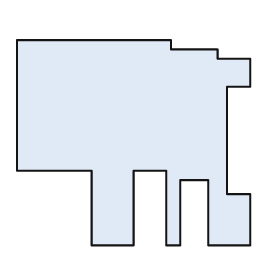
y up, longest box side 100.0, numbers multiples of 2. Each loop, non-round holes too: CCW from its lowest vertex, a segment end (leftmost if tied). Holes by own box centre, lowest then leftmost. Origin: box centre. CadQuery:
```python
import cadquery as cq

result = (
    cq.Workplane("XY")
    .moveTo(-18.0, -44.0)
    .lineTo(0.0, -44.0)
    .lineTo(0.0, -12.0)
    .lineTo(14.0, -12.0)
    .lineTo(14.0, -44.0)
    .lineTo(20.0, -44.0)
    .lineTo(20.0, -16.0)
    .lineTo(32.0, -16.0)
    .lineTo(32.0, -44.0)
    .lineTo(50.0, -44.0)
    .lineTo(50.0, -22.0)
    .lineTo(40.0, -22.0)
    .lineTo(40.0, 24.0)
    .lineTo(50.0, 24.0)
    .lineTo(50.0, 36.0)
    .lineTo(36.0, 36.0)
    .lineTo(36.0, 40.0)
    .lineTo(16.0, 40.0)
    .lineTo(16.0, 44.0)
    .lineTo(-50.0, 44.0)
    .lineTo(-50.0, -12.0)
    .lineTo(-18.0, -12.0)
    .close()
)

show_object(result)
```